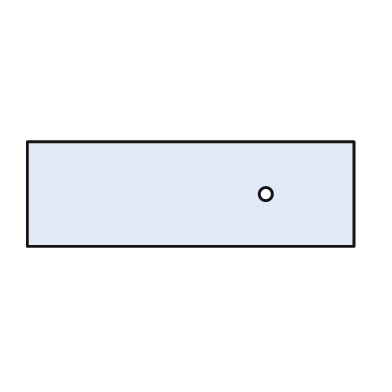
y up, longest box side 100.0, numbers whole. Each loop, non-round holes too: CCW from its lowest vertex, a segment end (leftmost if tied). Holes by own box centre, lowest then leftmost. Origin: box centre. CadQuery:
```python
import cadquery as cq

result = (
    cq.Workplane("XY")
    .moveTo(-50.0, -16.0)
    .lineTo(50.0, -16.0)
    .lineTo(50.0, 16.0)
    .lineTo(-50.0, 16.0)
    .close()
    .moveTo(23.0, 0.0)
    .circle(2.0)
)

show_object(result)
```